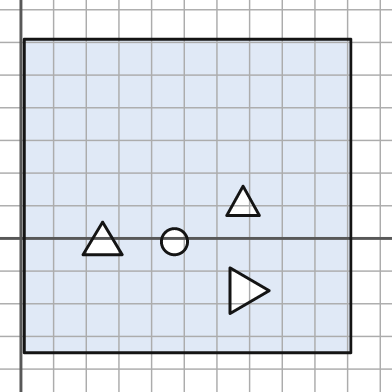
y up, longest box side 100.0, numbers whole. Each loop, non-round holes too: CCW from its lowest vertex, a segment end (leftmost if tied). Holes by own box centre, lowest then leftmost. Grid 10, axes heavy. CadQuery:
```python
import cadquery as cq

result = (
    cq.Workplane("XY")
    .moveTo(1.0, -35.0)
    .lineTo(101.0, -35.0)
    .lineTo(101.0, 61.0)
    .lineTo(1.0, 61.0)
    .close()
    .moveTo(64.0, -23.0)
    .lineTo(76.0, -16.0)
    .lineTo(64.0, -9.0)
    .close()
    .moveTo(47.0, -1.0)
    .circle(4.0)
    .moveTo(19.0, -5.0)
    .lineTo(31.0, -5.0)
    .lineTo(25.0, 5.0)
    .close()
    .moveTo(63.0, 7.0)
    .lineTo(73.0, 7.0)
    .lineTo(68.0, 16.0)
    .close()
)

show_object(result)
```